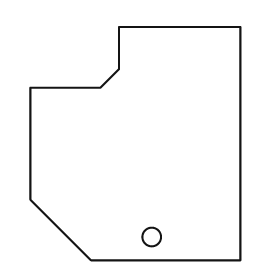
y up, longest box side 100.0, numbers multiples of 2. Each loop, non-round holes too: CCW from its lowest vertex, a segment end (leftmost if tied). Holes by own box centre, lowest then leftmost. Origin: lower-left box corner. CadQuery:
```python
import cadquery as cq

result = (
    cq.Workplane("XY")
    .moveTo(26.0, 0.0)
    .lineTo(90.0, 0.0)
    .lineTo(90.0, 100.0)
    .lineTo(38.0, 100.0)
    .lineTo(38.0, 82.0)
    .lineTo(30.0, 74.0)
    .lineTo(0.0, 74.0)
    .lineTo(0.0, 26.0)
    .close()
    .moveTo(52.0, 10.0)
    .circle(4.0)
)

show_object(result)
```